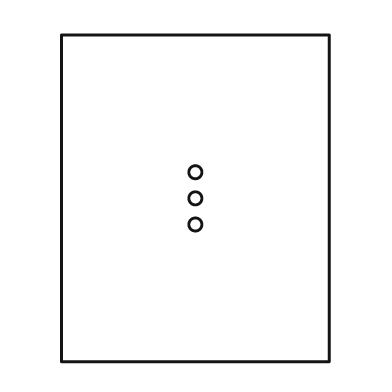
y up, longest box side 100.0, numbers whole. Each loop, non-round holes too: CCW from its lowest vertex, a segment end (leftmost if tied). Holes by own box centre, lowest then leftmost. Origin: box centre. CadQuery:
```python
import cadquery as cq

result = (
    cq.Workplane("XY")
    .moveTo(-41.0, -50.0)
    .lineTo(41.0, -50.0)
    .lineTo(41.0, 50.0)
    .lineTo(-41.0, 50.0)
    .close()
    .moveTo(0.0, -8.0)
    .circle(2.0)
    .moveTo(0.0, 0.0)
    .circle(2.0)
    .moveTo(0.0, 8.0)
    .circle(2.0)
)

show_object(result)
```